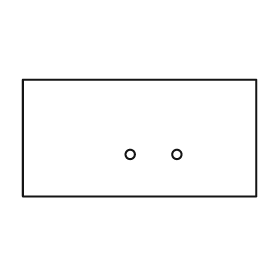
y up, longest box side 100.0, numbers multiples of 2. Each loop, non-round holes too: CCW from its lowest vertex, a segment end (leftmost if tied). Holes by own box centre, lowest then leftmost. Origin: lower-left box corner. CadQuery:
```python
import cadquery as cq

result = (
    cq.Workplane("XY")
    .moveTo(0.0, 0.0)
    .lineTo(100.0, 0.0)
    .lineTo(100.0, 50.0)
    .lineTo(0.0, 50.0)
    .close()
    .moveTo(46.0, 18.0)
    .circle(2.0)
    .moveTo(66.0, 18.0)
    .circle(2.0)
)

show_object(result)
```